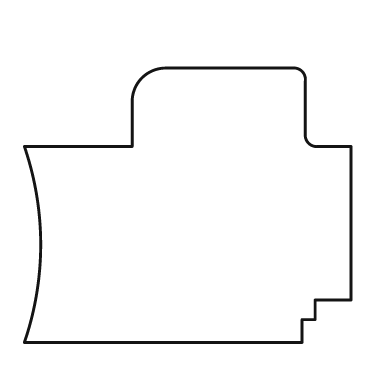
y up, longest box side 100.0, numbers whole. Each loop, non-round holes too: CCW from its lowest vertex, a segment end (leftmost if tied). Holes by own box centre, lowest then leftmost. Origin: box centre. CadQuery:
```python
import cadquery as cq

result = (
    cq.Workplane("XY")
    .moveTo(-50.0, -42.0)
    .lineTo(35.0, -42.0)
    .lineTo(35.0, -35.0)
    .lineTo(39.0, -35.0)
    .lineTo(39.0, -29.0)
    .lineTo(50.0, -29.0)
    .lineTo(50.0, 18.0)
    .lineTo(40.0, 18.0)
    .threePointArc((37.0, 19.0), (36.0, 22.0))
    .lineTo(36.0, 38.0)
    .threePointArc((35.0, 41.0), (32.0, 42.0))
    .lineTo(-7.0, 42.0)
    .threePointArc((-14.0, 39.0), (-17.0, 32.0))
    .lineTo(-17.0, 18.0)
    .lineTo(-50.0, 18.0)
    .threePointArc((-45.0, -12.0), (-50.0, -42.0))
    .close()
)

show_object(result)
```